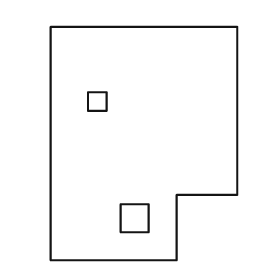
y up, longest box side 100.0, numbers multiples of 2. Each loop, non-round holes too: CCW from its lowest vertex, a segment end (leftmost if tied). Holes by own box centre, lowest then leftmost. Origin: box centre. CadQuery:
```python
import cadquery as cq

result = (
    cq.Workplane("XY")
    .moveTo(-40.0, -50.0)
    .lineTo(14.0, -50.0)
    .lineTo(14.0, -22.0)
    .lineTo(40.0, -22.0)
    .lineTo(40.0, 50.0)
    .lineTo(-40.0, 50.0)
    .close()
    .moveTo(-10.0, -38.0)
    .lineTo(2.0, -38.0)
    .lineTo(2.0, -26.0)
    .lineTo(-10.0, -26.0)
    .close()
    .moveTo(-24.0, 14.0)
    .lineTo(-16.0, 14.0)
    .lineTo(-16.0, 22.0)
    .lineTo(-24.0, 22.0)
    .close()
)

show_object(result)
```